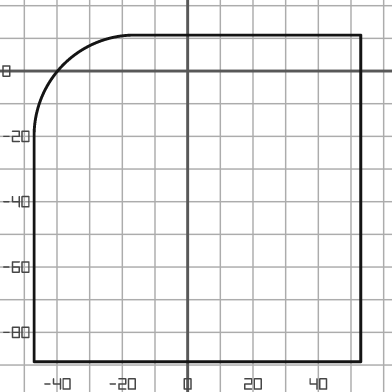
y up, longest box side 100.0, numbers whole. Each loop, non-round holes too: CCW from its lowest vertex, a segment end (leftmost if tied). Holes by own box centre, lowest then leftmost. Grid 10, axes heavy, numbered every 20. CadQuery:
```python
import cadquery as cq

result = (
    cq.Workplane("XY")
    .moveTo(-47.0, -89.0)
    .lineTo(53.0, -89.0)
    .lineTo(53.0, 11.0)
    .lineTo(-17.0, 11.0)
    .threePointArc((-38.0, 2.0), (-47.0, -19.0))
    .close()
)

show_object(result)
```